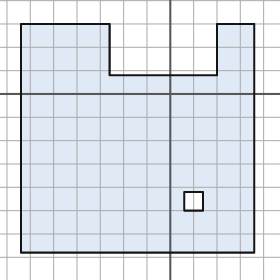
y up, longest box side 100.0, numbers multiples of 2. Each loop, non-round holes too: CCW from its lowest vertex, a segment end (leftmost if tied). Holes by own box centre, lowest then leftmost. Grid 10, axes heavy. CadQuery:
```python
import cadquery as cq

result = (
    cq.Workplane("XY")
    .moveTo(-64.0, -68.0)
    .lineTo(36.0, -68.0)
    .lineTo(36.0, 30.0)
    .lineTo(20.0, 30.0)
    .lineTo(20.0, 8.0)
    .lineTo(-26.0, 8.0)
    .lineTo(-26.0, 30.0)
    .lineTo(-64.0, 30.0)
    .close()
    .moveTo(6.0, -50.0)
    .lineTo(14.0, -50.0)
    .lineTo(14.0, -42.0)
    .lineTo(6.0, -42.0)
    .close()
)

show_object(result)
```